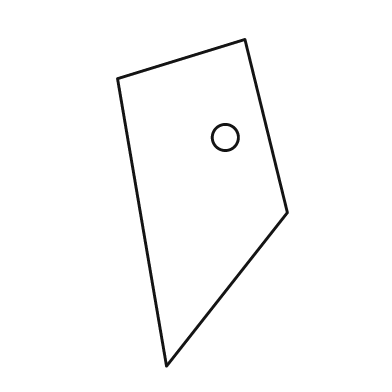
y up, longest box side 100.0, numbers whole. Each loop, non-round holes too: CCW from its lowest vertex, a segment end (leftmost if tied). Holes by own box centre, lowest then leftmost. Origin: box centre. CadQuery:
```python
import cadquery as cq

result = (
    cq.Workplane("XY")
    .moveTo(-11.0, -50.0)
    .lineTo(26.0, -3.0)
    .lineTo(13.0, 50.0)
    .lineTo(-26.0, 38.0)
    .close()
    .moveTo(7.0, 20.0)
    .circle(4.0)
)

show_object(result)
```